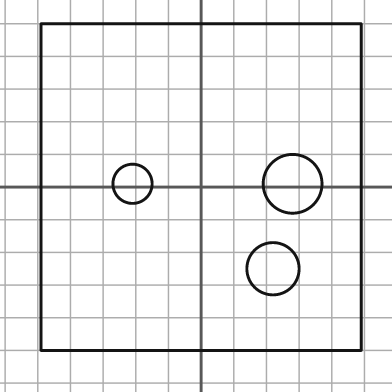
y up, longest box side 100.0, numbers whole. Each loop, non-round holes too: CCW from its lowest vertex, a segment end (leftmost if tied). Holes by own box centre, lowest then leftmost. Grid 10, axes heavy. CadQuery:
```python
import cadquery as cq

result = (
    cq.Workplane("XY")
    .moveTo(-49.0, -50.0)
    .lineTo(49.0, -50.0)
    .lineTo(49.0, 50.0)
    .lineTo(-49.0, 50.0)
    .close()
    .moveTo(22.0, -25.0)
    .circle(8.0)
    .moveTo(-21.0, 1.0)
    .circle(6.0)
    .moveTo(28.0, 1.0)
    .circle(9.0)
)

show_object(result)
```